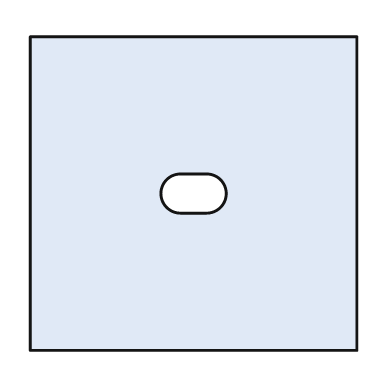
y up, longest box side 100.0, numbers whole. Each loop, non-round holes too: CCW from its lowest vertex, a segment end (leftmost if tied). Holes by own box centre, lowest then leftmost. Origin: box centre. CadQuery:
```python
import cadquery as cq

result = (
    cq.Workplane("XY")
    .moveTo(-50.0, -48.0)
    .lineTo(50.0, -48.0)
    .lineTo(50.0, 48.0)
    .lineTo(-50.0, 48.0)
    .close()
    .moveTo(-4.0, -6.0)
    .lineTo(4.0, -6.0)
    .threePointArc((10.0, 0.0), (4.0, 6.0))
    .lineTo(-4.0, 6.0)
    .threePointArc((-10.0, 0.0), (-4.0, -6.0))
    .close()
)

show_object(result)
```